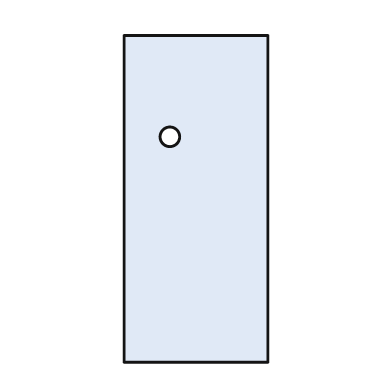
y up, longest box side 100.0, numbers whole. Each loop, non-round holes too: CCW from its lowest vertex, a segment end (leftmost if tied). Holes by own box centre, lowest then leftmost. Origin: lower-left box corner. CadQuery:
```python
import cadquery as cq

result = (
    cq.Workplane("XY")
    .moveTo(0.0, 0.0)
    .lineTo(44.0, 0.0)
    .lineTo(44.0, 100.0)
    .lineTo(0.0, 100.0)
    .close()
    .moveTo(14.0, 69.0)
    .circle(3.0)
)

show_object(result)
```